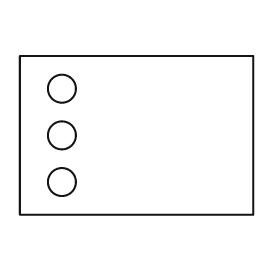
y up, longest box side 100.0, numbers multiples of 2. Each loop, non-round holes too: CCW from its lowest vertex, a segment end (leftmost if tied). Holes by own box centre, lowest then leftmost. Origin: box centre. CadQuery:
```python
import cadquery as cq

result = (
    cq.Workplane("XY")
    .moveTo(-50.0, -34.0)
    .lineTo(50.0, -34.0)
    .lineTo(50.0, 34.0)
    .lineTo(-50.0, 34.0)
    .close()
    .moveTo(-32.0, -20.0)
    .circle(6.0)
    .moveTo(-32.0, 0.0)
    .circle(6.0)
    .moveTo(-32.0, 20.0)
    .circle(6.0)
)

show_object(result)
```